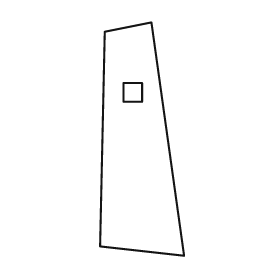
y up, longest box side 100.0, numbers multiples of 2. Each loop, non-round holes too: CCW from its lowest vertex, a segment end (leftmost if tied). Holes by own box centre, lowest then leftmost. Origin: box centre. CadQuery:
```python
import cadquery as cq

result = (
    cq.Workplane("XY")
    .moveTo(18.0, -50.0)
    .lineTo(4.0, 50.0)
    .lineTo(-16.0, 46.0)
    .lineTo(-18.0, -46.0)
    .close()
    .moveTo(-8.0, 16.0)
    .lineTo(0.0, 16.0)
    .lineTo(0.0, 24.0)
    .lineTo(-8.0, 24.0)
    .close()
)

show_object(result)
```